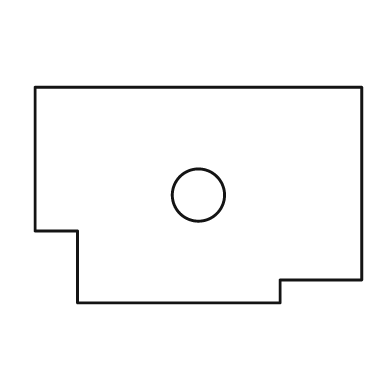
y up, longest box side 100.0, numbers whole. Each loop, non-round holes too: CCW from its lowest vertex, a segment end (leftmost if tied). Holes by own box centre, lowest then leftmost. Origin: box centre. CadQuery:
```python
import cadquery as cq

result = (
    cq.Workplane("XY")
    .moveTo(-37.0, -33.0)
    .lineTo(25.0, -33.0)
    .lineTo(25.0, -26.0)
    .lineTo(50.0, -26.0)
    .lineTo(50.0, 33.0)
    .lineTo(-50.0, 33.0)
    .lineTo(-50.0, -11.0)
    .lineTo(-37.0, -11.0)
    .close()
    .moveTo(0.0, 0.0)
    .circle(8.0)
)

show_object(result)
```